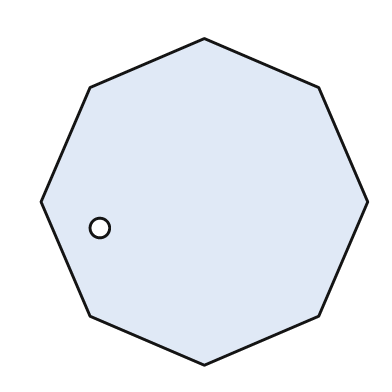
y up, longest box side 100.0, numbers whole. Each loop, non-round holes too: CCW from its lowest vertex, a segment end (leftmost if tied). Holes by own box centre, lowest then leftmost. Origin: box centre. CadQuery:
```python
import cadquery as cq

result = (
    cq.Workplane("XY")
    .moveTo(0.0, -50.0)
    .lineTo(35.0, -35.0)
    .lineTo(50.0, 0.0)
    .lineTo(35.0, 35.0)
    .lineTo(0.0, 50.0)
    .lineTo(-35.0, 35.0)
    .lineTo(-50.0, 0.0)
    .lineTo(-35.0, -35.0)
    .close()
    .moveTo(-32.0, -8.0)
    .circle(3.0)
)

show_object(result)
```